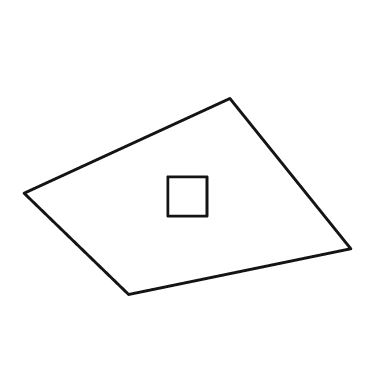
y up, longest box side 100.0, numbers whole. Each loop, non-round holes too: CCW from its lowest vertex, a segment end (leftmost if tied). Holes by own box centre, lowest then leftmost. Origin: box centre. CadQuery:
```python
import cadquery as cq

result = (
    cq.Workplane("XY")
    .moveTo(-18.0, -30.0)
    .lineTo(50.0, -16.0)
    .lineTo(13.0, 30.0)
    .lineTo(-50.0, 1.0)
    .close()
    .moveTo(-6.0, -6.0)
    .lineTo(6.0, -6.0)
    .lineTo(6.0, 6.0)
    .lineTo(-6.0, 6.0)
    .close()
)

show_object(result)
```